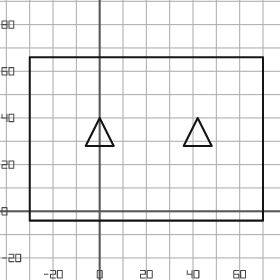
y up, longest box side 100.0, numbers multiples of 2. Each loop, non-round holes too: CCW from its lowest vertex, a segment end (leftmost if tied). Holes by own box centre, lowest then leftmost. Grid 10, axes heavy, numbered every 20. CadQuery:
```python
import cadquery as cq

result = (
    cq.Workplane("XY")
    .moveTo(-30.0, -4.0)
    .lineTo(70.0, -4.0)
    .lineTo(70.0, 66.0)
    .lineTo(-30.0, 66.0)
    .close()
    .moveTo(-6.0, 28.0)
    .lineTo(6.0, 28.0)
    .lineTo(0.0, 40.0)
    .close()
    .moveTo(36.0, 28.0)
    .lineTo(48.0, 28.0)
    .lineTo(42.0, 40.0)
    .close()
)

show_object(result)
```